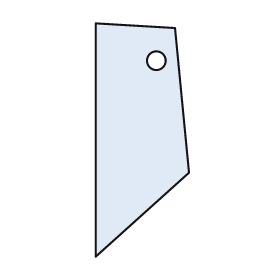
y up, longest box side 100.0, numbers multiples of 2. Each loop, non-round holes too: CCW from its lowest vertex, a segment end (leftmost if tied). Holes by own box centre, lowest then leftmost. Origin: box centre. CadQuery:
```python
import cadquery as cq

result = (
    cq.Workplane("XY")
    .moveTo(-20.0, -50.0)
    .lineTo(20.0, -14.0)
    .lineTo(14.0, 48.0)
    .lineTo(-20.0, 50.0)
    .close()
    .moveTo(6.0, 34.0)
    .circle(4.0)
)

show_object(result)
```